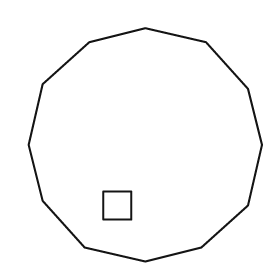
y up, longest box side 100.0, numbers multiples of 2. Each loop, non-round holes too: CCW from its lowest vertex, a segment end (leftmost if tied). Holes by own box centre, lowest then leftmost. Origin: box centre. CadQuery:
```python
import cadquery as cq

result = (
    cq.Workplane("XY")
    .moveTo(0.0, -50.0)
    .lineTo(24.0, -44.0)
    .lineTo(44.0, -26.0)
    .lineTo(50.0, 0.0)
    .lineTo(44.0, 24.0)
    .lineTo(26.0, 44.0)
    .lineTo(0.0, 50.0)
    .lineTo(-24.0, 44.0)
    .lineTo(-44.0, 26.0)
    .lineTo(-50.0, 0.0)
    .lineTo(-44.0, -24.0)
    .lineTo(-26.0, -44.0)
    .close()
    .moveTo(-18.0, -32.0)
    .lineTo(-6.0, -32.0)
    .lineTo(-6.0, -20.0)
    .lineTo(-18.0, -20.0)
    .close()
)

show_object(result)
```